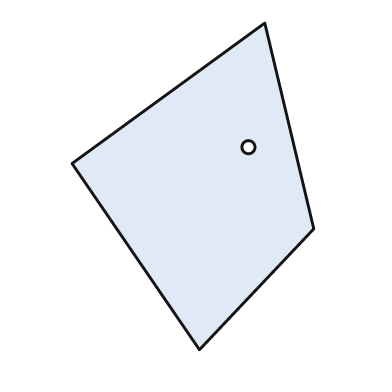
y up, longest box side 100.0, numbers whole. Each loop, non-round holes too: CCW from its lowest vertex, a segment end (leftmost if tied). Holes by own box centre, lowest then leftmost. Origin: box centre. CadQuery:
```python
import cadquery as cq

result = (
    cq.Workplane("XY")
    .moveTo(2.0, -50.0)
    .lineTo(37.0, -13.0)
    .lineTo(22.0, 50.0)
    .lineTo(-37.0, 7.0)
    .close()
    .moveTo(17.0, 12.0)
    .circle(2.0)
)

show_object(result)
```